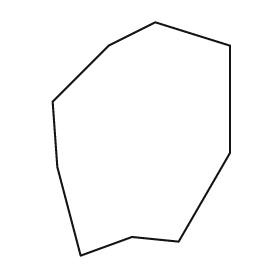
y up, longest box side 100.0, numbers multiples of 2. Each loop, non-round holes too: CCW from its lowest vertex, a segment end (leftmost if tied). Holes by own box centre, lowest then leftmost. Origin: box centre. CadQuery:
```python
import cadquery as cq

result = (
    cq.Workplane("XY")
    .moveTo(-26.0, -50.0)
    .lineTo(-4.0, -42.0)
    .lineTo(16.0, -44.0)
    .lineTo(38.0, -6.0)
    .lineTo(38.0, 40.0)
    .lineTo(6.0, 50.0)
    .lineTo(-14.0, 40.0)
    .lineTo(-38.0, 16.0)
    .lineTo(-36.0, -12.0)
    .close()
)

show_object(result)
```